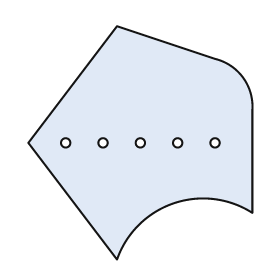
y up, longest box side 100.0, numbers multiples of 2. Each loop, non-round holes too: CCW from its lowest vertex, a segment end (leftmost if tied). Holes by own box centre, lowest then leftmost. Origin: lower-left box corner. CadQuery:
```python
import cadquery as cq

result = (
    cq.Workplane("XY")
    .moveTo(38.0, 0.0)
    .threePointArc((62.0, 24.0), (96.0, 20.0))
    .lineTo(96.0, 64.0)
    .threePointArc((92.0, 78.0), (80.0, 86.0))
    .lineTo(38.0, 100.0)
    .lineTo(0.0, 50.0)
    .close()
    .moveTo(16.0, 50.0)
    .circle(2.0)
    .moveTo(32.0, 50.0)
    .circle(2.0)
    .moveTo(48.0, 50.0)
    .circle(2.0)
    .moveTo(64.0, 50.0)
    .circle(2.0)
    .moveTo(80.0, 50.0)
    .circle(2.0)
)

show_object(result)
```